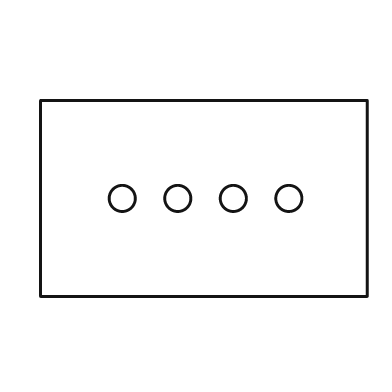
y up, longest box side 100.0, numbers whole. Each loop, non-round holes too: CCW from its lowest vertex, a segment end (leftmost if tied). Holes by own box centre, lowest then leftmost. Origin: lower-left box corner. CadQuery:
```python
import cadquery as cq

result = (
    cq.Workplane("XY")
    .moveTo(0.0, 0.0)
    .lineTo(100.0, 0.0)
    .lineTo(100.0, 60.0)
    .lineTo(0.0, 60.0)
    .close()
    .moveTo(25.0, 30.0)
    .circle(4.0)
    .moveTo(42.0, 30.0)
    .circle(4.0)
    .moveTo(59.0, 30.0)
    .circle(4.0)
    .moveTo(76.0, 30.0)
    .circle(4.0)
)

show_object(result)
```